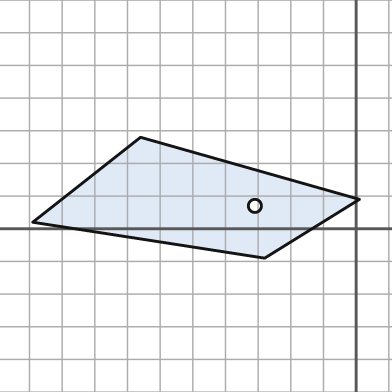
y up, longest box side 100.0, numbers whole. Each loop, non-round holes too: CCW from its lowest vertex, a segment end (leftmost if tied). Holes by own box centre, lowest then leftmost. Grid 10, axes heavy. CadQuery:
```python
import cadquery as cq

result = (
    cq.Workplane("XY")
    .moveTo(-28.0, -9.0)
    .lineTo(1.0, 9.0)
    .lineTo(-66.0, 28.0)
    .lineTo(-99.0, 2.0)
    .close()
    .moveTo(-31.0, 7.0)
    .circle(2.0)
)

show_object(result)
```